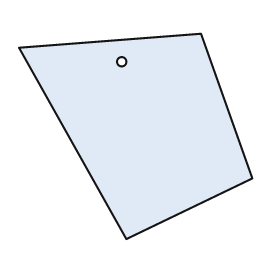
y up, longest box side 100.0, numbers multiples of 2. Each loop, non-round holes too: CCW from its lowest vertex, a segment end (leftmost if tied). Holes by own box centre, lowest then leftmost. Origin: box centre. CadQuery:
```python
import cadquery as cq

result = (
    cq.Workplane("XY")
    .moveTo(-4.0, -44.0)
    .lineTo(50.0, -18.0)
    .lineTo(28.0, 44.0)
    .lineTo(-50.0, 38.0)
    .close()
    .moveTo(-6.0, 32.0)
    .circle(2.0)
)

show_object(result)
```